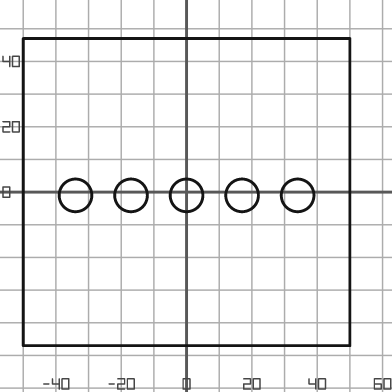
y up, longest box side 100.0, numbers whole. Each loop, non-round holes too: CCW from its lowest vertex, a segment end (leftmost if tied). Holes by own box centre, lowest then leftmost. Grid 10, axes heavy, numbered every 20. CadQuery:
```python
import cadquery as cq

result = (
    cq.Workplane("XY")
    .moveTo(-50.0, -47.0)
    .lineTo(50.0, -47.0)
    .lineTo(50.0, 47.0)
    .lineTo(-50.0, 47.0)
    .close()
    .moveTo(-34.0, -1.0)
    .circle(5.0)
    .moveTo(-17.0, -1.0)
    .circle(5.0)
    .moveTo(0.0, -1.0)
    .circle(5.0)
    .moveTo(17.0, -1.0)
    .circle(5.0)
    .moveTo(34.0, -1.0)
    .circle(5.0)
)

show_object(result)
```